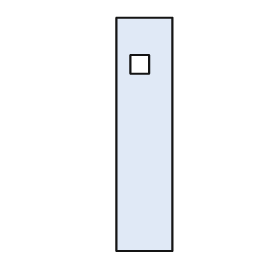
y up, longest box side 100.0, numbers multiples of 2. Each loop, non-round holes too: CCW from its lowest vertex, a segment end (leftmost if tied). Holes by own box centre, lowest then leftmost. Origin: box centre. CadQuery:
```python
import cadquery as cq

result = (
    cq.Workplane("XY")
    .moveTo(-12.0, -50.0)
    .lineTo(12.0, -50.0)
    .lineTo(12.0, 50.0)
    .lineTo(-12.0, 50.0)
    .close()
    .moveTo(-6.0, 26.0)
    .lineTo(2.0, 26.0)
    .lineTo(2.0, 34.0)
    .lineTo(-6.0, 34.0)
    .close()
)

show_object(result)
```